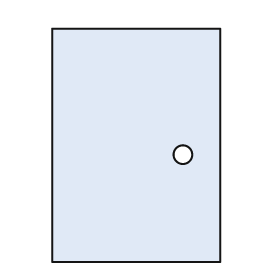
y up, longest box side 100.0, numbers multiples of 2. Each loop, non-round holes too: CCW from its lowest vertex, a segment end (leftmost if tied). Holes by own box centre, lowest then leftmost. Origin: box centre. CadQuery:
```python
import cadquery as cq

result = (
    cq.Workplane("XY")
    .moveTo(-36.0, -50.0)
    .lineTo(36.0, -50.0)
    .lineTo(36.0, 50.0)
    .lineTo(-36.0, 50.0)
    .close()
    .moveTo(20.0, -4.0)
    .circle(4.0)
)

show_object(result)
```